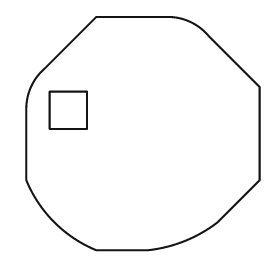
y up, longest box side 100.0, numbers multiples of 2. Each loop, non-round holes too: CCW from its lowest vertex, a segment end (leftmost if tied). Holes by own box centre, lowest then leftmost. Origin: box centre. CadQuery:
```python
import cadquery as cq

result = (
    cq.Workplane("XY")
    .moveTo(-20.0, -50.0)
    .lineTo(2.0, -50.0)
    .threePointArc((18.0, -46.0), (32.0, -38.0))
    .lineTo(50.0, -20.0)
    .lineTo(50.0, 20.0)
    .lineTo(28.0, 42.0)
    .threePointArc((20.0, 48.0), (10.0, 50.0))
    .lineTo(-20.0, 50.0)
    .lineTo(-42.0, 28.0)
    .threePointArc((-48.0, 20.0), (-50.0, 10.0))
    .lineTo(-50.0, -20.0)
    .threePointArc((-38.0, -38.0), (-20.0, -50.0))
    .close()
    .moveTo(-40.0, 2.0)
    .lineTo(-24.0, 2.0)
    .lineTo(-24.0, 18.0)
    .lineTo(-40.0, 18.0)
    .close()
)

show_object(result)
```